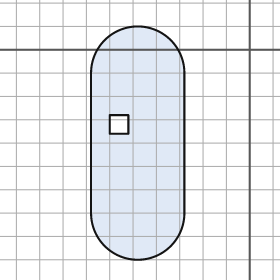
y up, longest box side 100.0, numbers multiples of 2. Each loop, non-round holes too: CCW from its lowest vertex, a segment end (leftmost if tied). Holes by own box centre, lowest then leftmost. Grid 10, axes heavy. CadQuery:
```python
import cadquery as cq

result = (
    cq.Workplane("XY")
    .moveTo(-68.0, -70.0)
    .threePointArc((-48.0, -90.0), (-28.0, -70.0))
    .lineTo(-28.0, -10.0)
    .threePointArc((-48.0, 10.0), (-68.0, -10.0))
    .close()
    .moveTo(-60.0, -36.0)
    .lineTo(-52.0, -36.0)
    .lineTo(-52.0, -28.0)
    .lineTo(-60.0, -28.0)
    .close()
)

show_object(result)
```